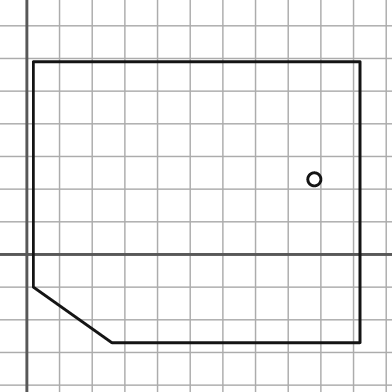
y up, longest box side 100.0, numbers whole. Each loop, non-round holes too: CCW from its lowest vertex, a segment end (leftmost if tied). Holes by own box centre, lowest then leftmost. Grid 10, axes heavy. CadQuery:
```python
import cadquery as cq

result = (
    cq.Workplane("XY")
    .moveTo(26.0, -27.0)
    .lineTo(102.0, -27.0)
    .lineTo(102.0, 59.0)
    .lineTo(2.0, 59.0)
    .lineTo(2.0, -10.0)
    .close()
    .moveTo(88.0, 23.0)
    .circle(2.0)
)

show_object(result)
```